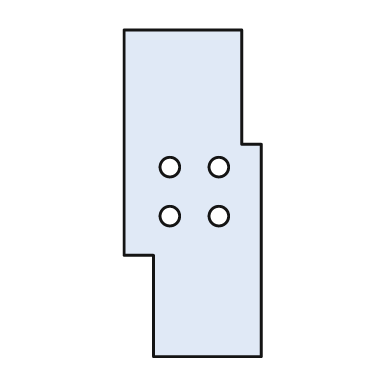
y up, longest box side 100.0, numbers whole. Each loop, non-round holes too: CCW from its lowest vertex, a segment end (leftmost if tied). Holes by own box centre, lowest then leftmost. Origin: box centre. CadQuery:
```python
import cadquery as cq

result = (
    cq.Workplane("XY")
    .moveTo(-12.0, -50.0)
    .lineTo(21.0, -50.0)
    .lineTo(21.0, 15.0)
    .lineTo(15.0, 15.0)
    .lineTo(15.0, 50.0)
    .lineTo(-21.0, 50.0)
    .lineTo(-21.0, -19.0)
    .lineTo(-12.0, -19.0)
    .close()
    .moveTo(-7.0, -7.0)
    .circle(3.0)
    .moveTo(8.0, -7.0)
    .circle(3.0)
    .moveTo(-7.0, 8.0)
    .circle(3.0)
    .moveTo(8.0, 8.0)
    .circle(3.0)
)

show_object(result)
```